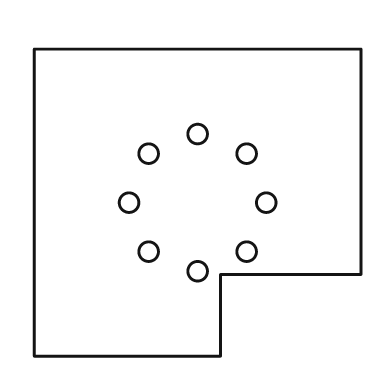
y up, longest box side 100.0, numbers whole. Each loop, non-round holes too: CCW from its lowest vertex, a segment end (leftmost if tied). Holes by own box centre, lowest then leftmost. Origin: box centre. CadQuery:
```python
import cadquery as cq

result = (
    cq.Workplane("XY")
    .moveTo(-50.0, -47.0)
    .lineTo(7.0, -47.0)
    .lineTo(7.0, -22.0)
    .lineTo(50.0, -22.0)
    .lineTo(50.0, 47.0)
    .lineTo(-50.0, 47.0)
    .close()
    .moveTo(0.0, -21.0)
    .circle(3.0)
    .moveTo(-15.0, -15.0)
    .circle(3.0)
    .moveTo(15.0, -15.0)
    .circle(3.0)
    .moveTo(-21.0, 0.0)
    .circle(3.0)
    .moveTo(21.0, 0.0)
    .circle(3.0)
    .moveTo(-15.0, 15.0)
    .circle(3.0)
    .moveTo(15.0, 15.0)
    .circle(3.0)
    .moveTo(0.0, 21.0)
    .circle(3.0)
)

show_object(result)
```